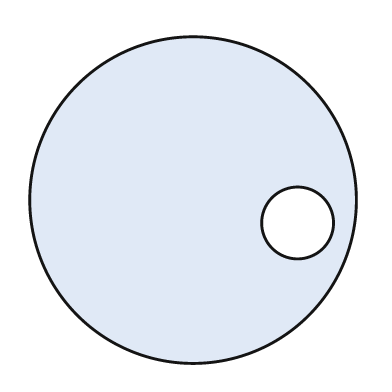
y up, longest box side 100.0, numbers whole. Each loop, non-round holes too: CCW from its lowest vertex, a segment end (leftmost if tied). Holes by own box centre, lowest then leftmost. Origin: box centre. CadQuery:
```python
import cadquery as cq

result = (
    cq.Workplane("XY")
    .moveTo(0.0, 0.0)
    .circle(50.0)
    .moveTo(32.0, -7.0)
    .circle(11.0)
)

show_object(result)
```